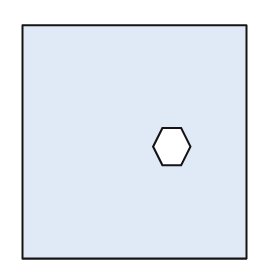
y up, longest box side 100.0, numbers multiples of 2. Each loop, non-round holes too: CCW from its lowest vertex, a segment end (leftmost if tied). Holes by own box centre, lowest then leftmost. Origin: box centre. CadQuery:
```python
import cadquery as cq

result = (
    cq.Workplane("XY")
    .moveTo(-48.0, -50.0)
    .lineTo(48.0, -50.0)
    .lineTo(48.0, 50.0)
    .lineTo(-48.0, 50.0)
    .close()
    .moveTo(12.0, -10.0)
    .lineTo(20.0, -10.0)
    .lineTo(24.0, -2.0)
    .lineTo(20.0, 6.0)
    .lineTo(12.0, 6.0)
    .lineTo(8.0, -2.0)
    .close()
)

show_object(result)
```